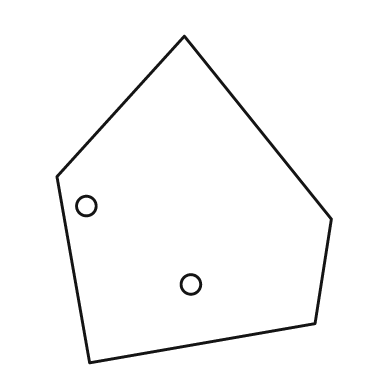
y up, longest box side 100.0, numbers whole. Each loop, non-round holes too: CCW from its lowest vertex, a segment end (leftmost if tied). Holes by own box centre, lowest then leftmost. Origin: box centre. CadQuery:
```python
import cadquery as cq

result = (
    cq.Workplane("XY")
    .moveTo(-32.0, -50.0)
    .lineTo(37.0, -38.0)
    .lineTo(42.0, -6.0)
    .lineTo(-3.0, 50.0)
    .lineTo(-42.0, 7.0)
    .close()
    .moveTo(-1.0, -26.0)
    .circle(3.0)
    .moveTo(-33.0, -2.0)
    .circle(3.0)
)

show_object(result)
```